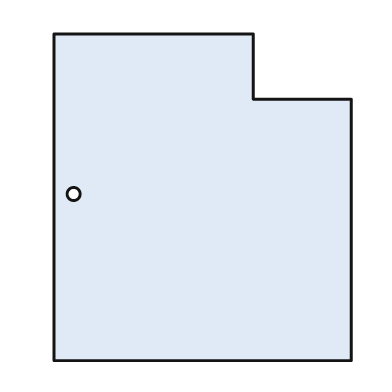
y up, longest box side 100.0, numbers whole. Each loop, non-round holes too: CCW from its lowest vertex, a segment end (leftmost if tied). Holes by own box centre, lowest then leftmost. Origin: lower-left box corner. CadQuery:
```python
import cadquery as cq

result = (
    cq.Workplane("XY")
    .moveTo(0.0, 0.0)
    .lineTo(91.0, 0.0)
    .lineTo(91.0, 80.0)
    .lineTo(61.0, 80.0)
    .lineTo(61.0, 100.0)
    .lineTo(0.0, 100.0)
    .close()
    .moveTo(6.0, 51.0)
    .circle(2.0)
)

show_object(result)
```